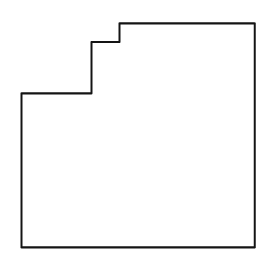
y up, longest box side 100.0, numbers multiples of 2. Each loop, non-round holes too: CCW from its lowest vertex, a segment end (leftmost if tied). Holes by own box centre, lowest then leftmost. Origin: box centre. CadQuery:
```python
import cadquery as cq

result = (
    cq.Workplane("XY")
    .moveTo(-50.0, -48.0)
    .lineTo(50.0, -48.0)
    .lineTo(50.0, 48.0)
    .lineTo(-8.0, 48.0)
    .lineTo(-8.0, 40.0)
    .lineTo(-20.0, 40.0)
    .lineTo(-20.0, 18.0)
    .lineTo(-50.0, 18.0)
    .close()
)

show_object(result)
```